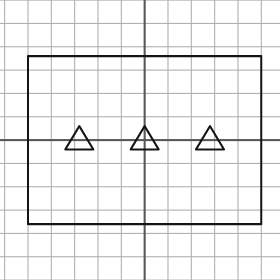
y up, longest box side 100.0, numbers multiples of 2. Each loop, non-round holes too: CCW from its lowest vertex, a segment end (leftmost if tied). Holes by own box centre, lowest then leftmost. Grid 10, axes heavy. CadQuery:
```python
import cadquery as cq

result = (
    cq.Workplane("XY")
    .moveTo(-50.0, -36.0)
    .lineTo(50.0, -36.0)
    .lineTo(50.0, 36.0)
    .lineTo(-50.0, 36.0)
    .close()
    .moveTo(-34.0, -4.0)
    .lineTo(-22.0, -4.0)
    .lineTo(-28.0, 6.0)
    .close()
    .moveTo(-6.0, -4.0)
    .lineTo(6.0, -4.0)
    .lineTo(0.0, 6.0)
    .close()
    .moveTo(22.0, -4.0)
    .lineTo(34.0, -4.0)
    .lineTo(28.0, 6.0)
    .close()
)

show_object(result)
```